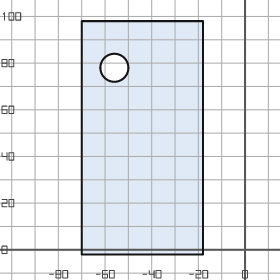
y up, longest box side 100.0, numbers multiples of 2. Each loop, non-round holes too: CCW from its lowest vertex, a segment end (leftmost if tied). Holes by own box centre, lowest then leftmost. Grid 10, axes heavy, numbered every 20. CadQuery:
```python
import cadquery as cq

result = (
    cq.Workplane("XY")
    .moveTo(-70.0, -2.0)
    .lineTo(-18.0, -2.0)
    .lineTo(-18.0, 98.0)
    .lineTo(-70.0, 98.0)
    .close()
    .moveTo(-56.0, 78.0)
    .circle(6.0)
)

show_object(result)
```